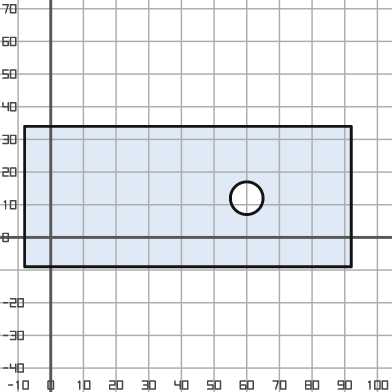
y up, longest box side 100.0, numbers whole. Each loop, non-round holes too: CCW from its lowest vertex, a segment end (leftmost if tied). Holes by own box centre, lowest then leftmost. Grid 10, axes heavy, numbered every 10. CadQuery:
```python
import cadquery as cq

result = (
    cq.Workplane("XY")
    .moveTo(-8.0, -9.0)
    .lineTo(92.0, -9.0)
    .lineTo(92.0, 34.0)
    .lineTo(-8.0, 34.0)
    .close()
    .moveTo(60.0, 12.0)
    .circle(5.0)
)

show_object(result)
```